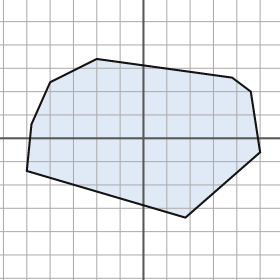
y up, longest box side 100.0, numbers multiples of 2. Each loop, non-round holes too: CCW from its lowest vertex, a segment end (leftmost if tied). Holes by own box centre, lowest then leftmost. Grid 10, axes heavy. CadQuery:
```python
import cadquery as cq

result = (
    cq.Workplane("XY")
    .moveTo(18.0, -34.0)
    .lineTo(50.0, -6.0)
    .lineTo(46.0, 20.0)
    .lineTo(38.0, 26.0)
    .lineTo(-20.0, 34.0)
    .lineTo(-40.0, 24.0)
    .lineTo(-48.0, 6.0)
    .lineTo(-50.0, -14.0)
    .close()
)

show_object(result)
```